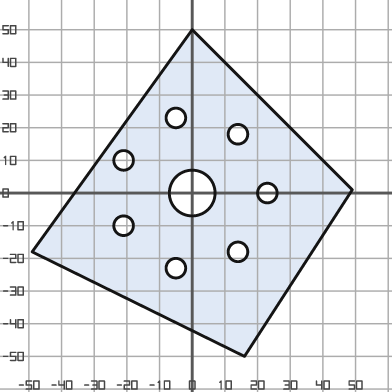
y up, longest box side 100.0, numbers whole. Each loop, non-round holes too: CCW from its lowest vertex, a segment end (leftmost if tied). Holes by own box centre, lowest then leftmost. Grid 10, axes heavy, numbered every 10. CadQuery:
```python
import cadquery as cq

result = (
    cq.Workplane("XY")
    .moveTo(16.0, -50.0)
    .lineTo(49.0, 1.0)
    .lineTo(0.0, 50.0)
    .lineTo(-49.0, -18.0)
    .close()
    .moveTo(-5.0, -23.0)
    .circle(3.0)
    .moveTo(14.0, -18.0)
    .circle(3.0)
    .moveTo(-21.0, -10.0)
    .circle(3.0)
    .moveTo(0.0, 0.0)
    .circle(7.0)
    .moveTo(23.0, 0.0)
    .circle(3.0)
    .moveTo(-21.0, 10.0)
    .circle(3.0)
    .moveTo(14.0, 18.0)
    .circle(3.0)
    .moveTo(-5.0, 23.0)
    .circle(3.0)
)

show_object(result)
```